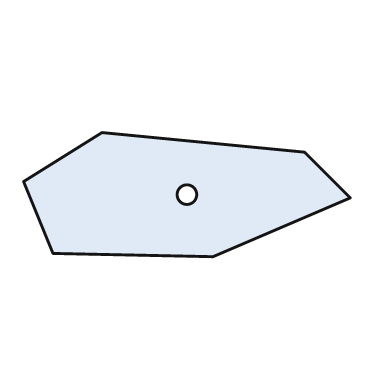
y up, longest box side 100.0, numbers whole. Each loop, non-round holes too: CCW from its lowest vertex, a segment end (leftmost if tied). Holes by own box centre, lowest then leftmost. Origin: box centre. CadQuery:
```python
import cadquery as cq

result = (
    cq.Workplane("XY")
    .moveTo(8.0, -19.0)
    .lineTo(50.0, -1.0)
    .lineTo(36.0, 13.0)
    .lineTo(-26.0, 19.0)
    .lineTo(-50.0, 4.0)
    .lineTo(-41.0, -18.0)
    .close()
    .moveTo(0.0, 0.0)
    .circle(3.0)
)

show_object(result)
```